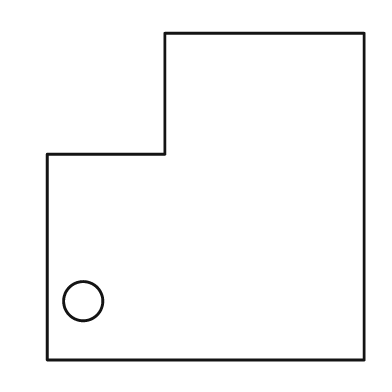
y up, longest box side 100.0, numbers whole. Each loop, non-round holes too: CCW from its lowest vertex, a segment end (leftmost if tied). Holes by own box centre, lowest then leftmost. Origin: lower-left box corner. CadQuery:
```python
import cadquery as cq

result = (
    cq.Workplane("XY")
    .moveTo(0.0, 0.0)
    .lineTo(97.0, 0.0)
    .lineTo(97.0, 100.0)
    .lineTo(36.0, 100.0)
    .lineTo(36.0, 63.0)
    .lineTo(0.0, 63.0)
    .close()
    .moveTo(11.0, 18.0)
    .circle(6.0)
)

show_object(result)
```